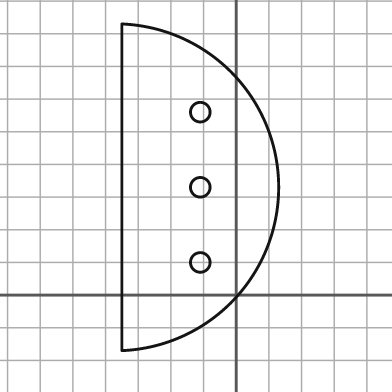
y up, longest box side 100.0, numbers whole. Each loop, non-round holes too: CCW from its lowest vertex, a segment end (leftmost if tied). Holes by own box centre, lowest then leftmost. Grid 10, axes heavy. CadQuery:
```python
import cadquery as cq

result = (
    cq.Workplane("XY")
    .moveTo(-35.0, -17.0)
    .threePointArc((13.0, 33.0), (-35.0, 83.0))
    .close()
    .moveTo(-11.0, 10.0)
    .circle(3.0)
    .moveTo(-11.0, 33.0)
    .circle(3.0)
    .moveTo(-11.0, 56.0)
    .circle(3.0)
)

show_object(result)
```